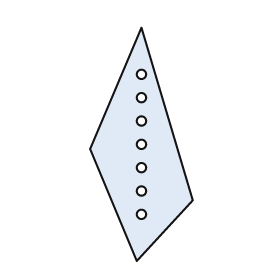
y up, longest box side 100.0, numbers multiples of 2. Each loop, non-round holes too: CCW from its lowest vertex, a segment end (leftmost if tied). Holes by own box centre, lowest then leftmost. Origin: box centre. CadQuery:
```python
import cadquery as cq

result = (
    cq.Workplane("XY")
    .moveTo(-2.0, -50.0)
    .lineTo(22.0, -24.0)
    .lineTo(0.0, 50.0)
    .lineTo(-22.0, -2.0)
    .close()
    .moveTo(0.0, -30.0)
    .circle(2.0)
    .moveTo(0.0, -20.0)
    .circle(2.0)
    .moveTo(0.0, -10.0)
    .circle(2.0)
    .moveTo(0.0, 0.0)
    .circle(2.0)
    .moveTo(0.0, 10.0)
    .circle(2.0)
    .moveTo(0.0, 20.0)
    .circle(2.0)
    .moveTo(0.0, 30.0)
    .circle(2.0)
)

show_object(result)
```